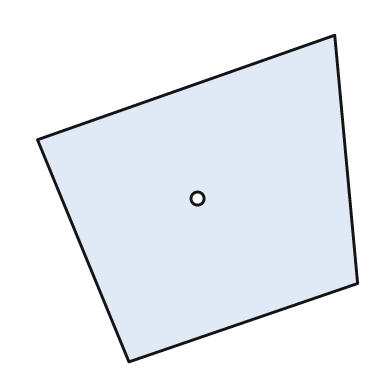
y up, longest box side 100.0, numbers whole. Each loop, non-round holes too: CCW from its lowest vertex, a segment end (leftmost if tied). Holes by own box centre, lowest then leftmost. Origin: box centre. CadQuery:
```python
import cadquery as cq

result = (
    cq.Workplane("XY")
    .moveTo(-21.0, -50.0)
    .lineTo(49.0, -26.0)
    .lineTo(42.0, 50.0)
    .lineTo(-49.0, 18.0)
    .close()
    .moveTo(0.0, 0.0)
    .circle(2.0)
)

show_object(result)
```